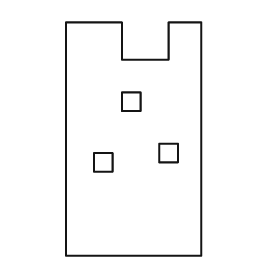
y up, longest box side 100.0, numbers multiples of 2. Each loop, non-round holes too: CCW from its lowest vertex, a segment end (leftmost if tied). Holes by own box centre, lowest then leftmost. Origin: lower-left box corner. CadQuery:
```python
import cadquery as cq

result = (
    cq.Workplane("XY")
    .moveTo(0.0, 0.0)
    .lineTo(58.0, 0.0)
    .lineTo(58.0, 100.0)
    .lineTo(44.0, 100.0)
    .lineTo(44.0, 84.0)
    .lineTo(24.0, 84.0)
    .lineTo(24.0, 100.0)
    .lineTo(0.0, 100.0)
    .close()
    .moveTo(12.0, 36.0)
    .lineTo(20.0, 36.0)
    .lineTo(20.0, 44.0)
    .lineTo(12.0, 44.0)
    .close()
    .moveTo(40.0, 40.0)
    .lineTo(48.0, 40.0)
    .lineTo(48.0, 48.0)
    .lineTo(40.0, 48.0)
    .close()
    .moveTo(24.0, 62.0)
    .lineTo(32.0, 62.0)
    .lineTo(32.0, 70.0)
    .lineTo(24.0, 70.0)
    .close()
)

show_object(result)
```